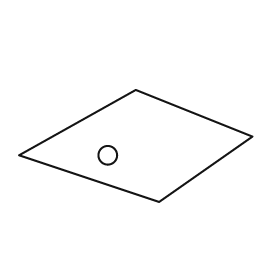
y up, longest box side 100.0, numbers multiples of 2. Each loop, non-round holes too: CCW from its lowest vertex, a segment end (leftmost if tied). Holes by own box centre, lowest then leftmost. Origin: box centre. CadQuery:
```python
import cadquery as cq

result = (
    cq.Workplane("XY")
    .moveTo(10.0, -24.0)
    .lineTo(50.0, 4.0)
    .lineTo(0.0, 24.0)
    .lineTo(-50.0, -4.0)
    .close()
    .moveTo(-12.0, -4.0)
    .circle(4.0)
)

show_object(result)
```